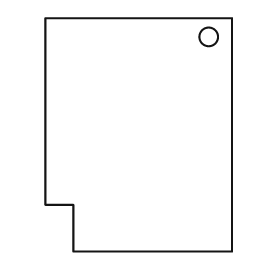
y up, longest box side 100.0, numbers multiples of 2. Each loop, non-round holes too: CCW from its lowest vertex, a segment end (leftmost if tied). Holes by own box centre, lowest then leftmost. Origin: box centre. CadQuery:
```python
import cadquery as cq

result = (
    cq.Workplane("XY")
    .moveTo(-28.0, -50.0)
    .lineTo(40.0, -50.0)
    .lineTo(40.0, 50.0)
    .lineTo(-40.0, 50.0)
    .lineTo(-40.0, -30.0)
    .lineTo(-28.0, -30.0)
    .close()
    .moveTo(30.0, 42.0)
    .circle(4.0)
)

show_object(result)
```